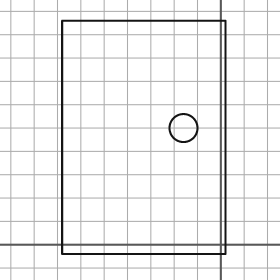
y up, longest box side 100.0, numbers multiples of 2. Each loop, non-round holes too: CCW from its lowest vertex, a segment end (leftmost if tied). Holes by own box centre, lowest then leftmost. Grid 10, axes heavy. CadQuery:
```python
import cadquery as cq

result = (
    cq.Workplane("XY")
    .moveTo(-68.0, -4.0)
    .lineTo(2.0, -4.0)
    .lineTo(2.0, 96.0)
    .lineTo(-68.0, 96.0)
    .close()
    .moveTo(-16.0, 50.0)
    .circle(6.0)
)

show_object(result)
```